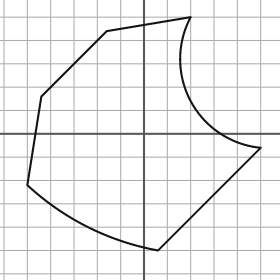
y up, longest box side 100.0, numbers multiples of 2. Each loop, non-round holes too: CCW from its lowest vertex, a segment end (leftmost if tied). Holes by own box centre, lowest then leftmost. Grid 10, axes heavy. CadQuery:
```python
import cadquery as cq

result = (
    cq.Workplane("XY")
    .moveTo(6.0, -50.0)
    .lineTo(50.0, -6.0)
    .threePointArc((20.0, 14.0), (20.0, 50.0))
    .lineTo(-16.0, 44.0)
    .lineTo(-44.0, 16.0)
    .lineTo(-50.0, -22.0)
    .threePointArc((-24.0, -40.0), (6.0, -50.0))
    .close()
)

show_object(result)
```